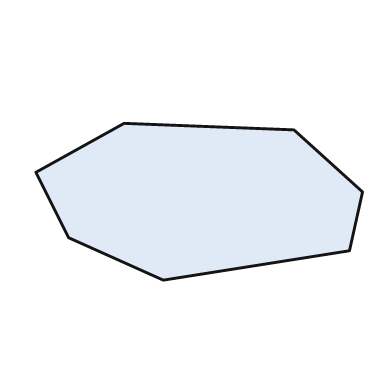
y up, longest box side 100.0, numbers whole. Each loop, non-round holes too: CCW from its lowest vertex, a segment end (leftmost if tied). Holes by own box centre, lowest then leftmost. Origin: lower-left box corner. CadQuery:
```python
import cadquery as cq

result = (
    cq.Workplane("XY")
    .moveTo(39.0, 0.0)
    .lineTo(96.0, 9.0)
    .lineTo(100.0, 27.0)
    .lineTo(79.0, 46.0)
    .lineTo(27.0, 48.0)
    .lineTo(0.0, 33.0)
    .lineTo(10.0, 13.0)
    .close()
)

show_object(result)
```